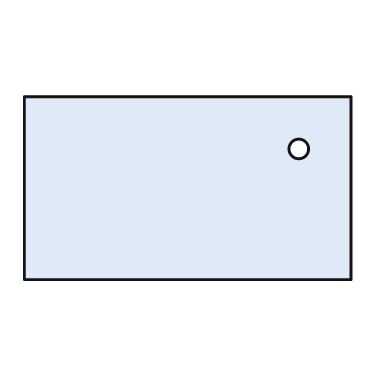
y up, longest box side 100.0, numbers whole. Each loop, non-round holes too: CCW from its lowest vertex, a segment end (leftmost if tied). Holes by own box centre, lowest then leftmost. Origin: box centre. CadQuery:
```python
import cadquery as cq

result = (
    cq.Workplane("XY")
    .moveTo(-50.0, -28.0)
    .lineTo(50.0, -28.0)
    .lineTo(50.0, 28.0)
    .lineTo(-50.0, 28.0)
    .close()
    .moveTo(34.0, 12.0)
    .circle(3.0)
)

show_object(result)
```